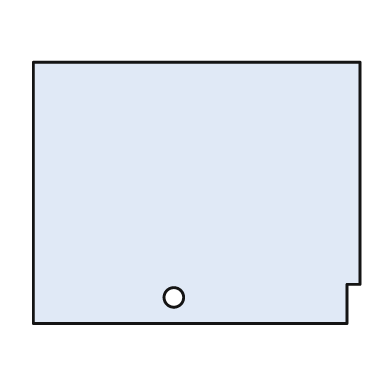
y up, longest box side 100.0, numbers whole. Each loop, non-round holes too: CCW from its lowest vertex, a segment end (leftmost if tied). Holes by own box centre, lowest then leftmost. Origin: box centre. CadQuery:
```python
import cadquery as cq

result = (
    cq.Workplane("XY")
    .moveTo(-50.0, -40.0)
    .lineTo(46.0, -40.0)
    .lineTo(46.0, -28.0)
    .lineTo(50.0, -28.0)
    .lineTo(50.0, 40.0)
    .lineTo(-50.0, 40.0)
    .close()
    .moveTo(-7.0, -32.0)
    .circle(3.0)
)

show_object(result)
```